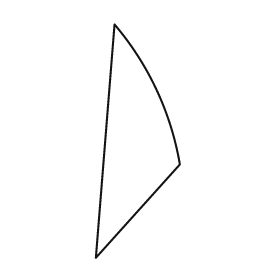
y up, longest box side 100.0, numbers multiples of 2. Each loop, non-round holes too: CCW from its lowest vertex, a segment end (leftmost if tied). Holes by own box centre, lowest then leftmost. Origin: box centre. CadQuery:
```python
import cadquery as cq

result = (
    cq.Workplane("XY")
    .moveTo(-18.0, -50.0)
    .lineTo(18.0, -10.0)
    .threePointArc((8.0, 22.0), (-10.0, 50.0))
    .close()
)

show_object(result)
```